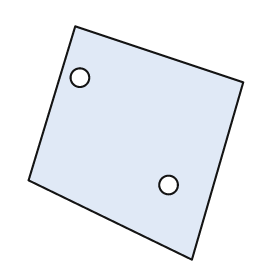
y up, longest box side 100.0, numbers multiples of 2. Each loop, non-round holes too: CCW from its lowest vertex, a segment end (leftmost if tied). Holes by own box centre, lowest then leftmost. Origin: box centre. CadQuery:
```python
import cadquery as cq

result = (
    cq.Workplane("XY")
    .moveTo(24.0, -50.0)
    .lineTo(46.0, 26.0)
    .lineTo(-26.0, 50.0)
    .lineTo(-46.0, -16.0)
    .close()
    .moveTo(14.0, -18.0)
    .circle(4.0)
    .moveTo(-24.0, 28.0)
    .circle(4.0)
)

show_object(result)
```